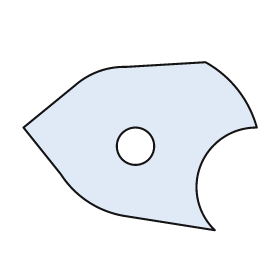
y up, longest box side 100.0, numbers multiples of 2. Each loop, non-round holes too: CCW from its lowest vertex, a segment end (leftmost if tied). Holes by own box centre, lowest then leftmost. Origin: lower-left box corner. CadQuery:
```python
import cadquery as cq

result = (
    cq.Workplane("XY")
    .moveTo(82.0, 0.0)
    .threePointArc((76.0, 28.0), (100.0, 44.0))
    .threePointArc((92.0, 60.0), (78.0, 72.0))
    .lineTo(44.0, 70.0)
    .threePointArc((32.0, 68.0), (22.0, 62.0))
    .lineTo(0.0, 44.0)
    .lineTo(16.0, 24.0)
    .threePointArc((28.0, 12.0), (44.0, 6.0))
    .close()
    .moveTo(48.0, 36.0)
    .circle(8.0)
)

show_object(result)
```